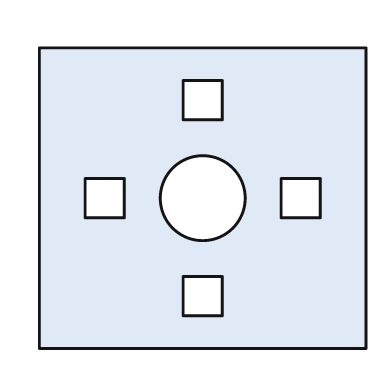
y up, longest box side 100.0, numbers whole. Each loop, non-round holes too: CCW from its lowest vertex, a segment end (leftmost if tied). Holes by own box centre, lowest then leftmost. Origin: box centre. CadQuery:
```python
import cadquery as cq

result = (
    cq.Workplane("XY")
    .moveTo(-50.0, -46.0)
    .lineTo(50.0, -46.0)
    .lineTo(50.0, 46.0)
    .lineTo(-50.0, 46.0)
    .close()
    .moveTo(-6.0, -36.0)
    .lineTo(6.0, -36.0)
    .lineTo(6.0, -24.0)
    .lineTo(-6.0, -24.0)
    .close()
    .moveTo(-36.0, -6.0)
    .lineTo(-24.0, -6.0)
    .lineTo(-24.0, 6.0)
    .lineTo(-36.0, 6.0)
    .close()
    .moveTo(0.0, 0.0)
    .circle(13.0)
    .moveTo(24.0, -6.0)
    .lineTo(36.0, -6.0)
    .lineTo(36.0, 6.0)
    .lineTo(24.0, 6.0)
    .close()
    .moveTo(-6.0, 24.0)
    .lineTo(6.0, 24.0)
    .lineTo(6.0, 36.0)
    .lineTo(-6.0, 36.0)
    .close()
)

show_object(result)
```